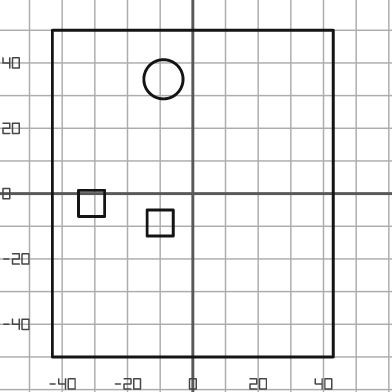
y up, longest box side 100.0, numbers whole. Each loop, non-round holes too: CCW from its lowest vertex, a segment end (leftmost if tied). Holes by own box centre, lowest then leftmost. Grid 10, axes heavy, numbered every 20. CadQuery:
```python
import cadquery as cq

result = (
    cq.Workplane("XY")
    .moveTo(-43.0, -50.0)
    .lineTo(43.0, -50.0)
    .lineTo(43.0, 50.0)
    .lineTo(-43.0, 50.0)
    .close()
    .moveTo(-14.0, -13.0)
    .lineTo(-6.0, -13.0)
    .lineTo(-6.0, -5.0)
    .lineTo(-14.0, -5.0)
    .close()
    .moveTo(-35.0, -7.0)
    .lineTo(-27.0, -7.0)
    .lineTo(-27.0, 1.0)
    .lineTo(-35.0, 1.0)
    .close()
    .moveTo(-9.0, 35.0)
    .circle(6.0)
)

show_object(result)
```